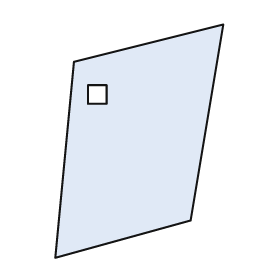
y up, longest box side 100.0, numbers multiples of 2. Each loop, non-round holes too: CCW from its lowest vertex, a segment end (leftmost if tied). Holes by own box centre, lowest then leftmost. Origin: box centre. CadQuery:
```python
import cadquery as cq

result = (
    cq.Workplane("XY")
    .moveTo(-36.0, -50.0)
    .lineTo(22.0, -34.0)
    .lineTo(36.0, 50.0)
    .lineTo(-28.0, 34.0)
    .close()
    .moveTo(-22.0, 16.0)
    .lineTo(-14.0, 16.0)
    .lineTo(-14.0, 24.0)
    .lineTo(-22.0, 24.0)
    .close()
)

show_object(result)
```